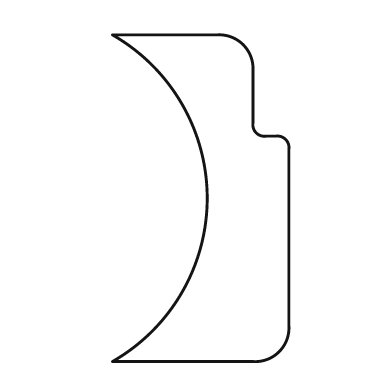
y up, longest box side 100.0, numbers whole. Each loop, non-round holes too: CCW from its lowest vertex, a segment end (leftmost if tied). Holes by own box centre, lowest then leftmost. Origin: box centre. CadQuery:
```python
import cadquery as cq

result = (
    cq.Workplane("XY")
    .moveTo(-27.0, -50.0)
    .lineTo(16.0, -50.0)
    .threePointArc((24.0, -47.0), (27.0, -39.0))
    .lineTo(27.0, 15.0)
    .threePointArc((26.0, 18.0), (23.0, 19.0))
    .lineTo(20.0, 19.0)
    .threePointArc((17.0, 20.0), (16.0, 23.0))
    .lineTo(16.0, 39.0)
    .threePointArc((13.0, 47.0), (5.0, 50.0))
    .lineTo(-27.0, 50.0)
    .threePointArc((2.0, 0.0), (-27.0, -50.0))
    .close()
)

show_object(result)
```